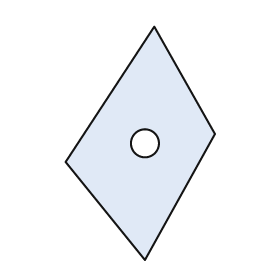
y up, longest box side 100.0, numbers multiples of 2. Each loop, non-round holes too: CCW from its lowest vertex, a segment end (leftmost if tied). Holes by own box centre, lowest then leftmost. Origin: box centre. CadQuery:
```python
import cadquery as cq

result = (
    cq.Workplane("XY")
    .moveTo(2.0, -50.0)
    .lineTo(32.0, 4.0)
    .lineTo(6.0, 50.0)
    .lineTo(-32.0, -8.0)
    .close()
    .moveTo(2.0, 0.0)
    .circle(6.0)
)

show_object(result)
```